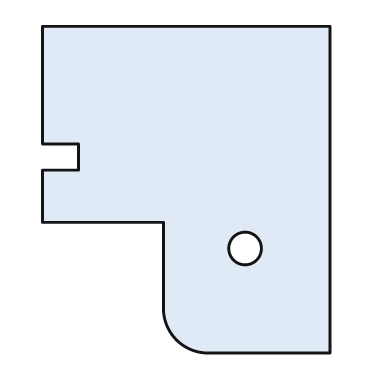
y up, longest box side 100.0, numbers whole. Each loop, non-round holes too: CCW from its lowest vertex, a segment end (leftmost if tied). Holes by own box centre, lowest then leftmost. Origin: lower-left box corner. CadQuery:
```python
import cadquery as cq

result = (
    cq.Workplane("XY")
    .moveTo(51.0, 0.0)
    .lineTo(88.0, 0.0)
    .lineTo(88.0, 100.0)
    .lineTo(0.0, 100.0)
    .lineTo(0.0, 64.0)
    .lineTo(11.0, 64.0)
    .lineTo(11.0, 56.0)
    .lineTo(0.0, 56.0)
    .lineTo(0.0, 40.0)
    .lineTo(37.0, 40.0)
    .lineTo(37.0, 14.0)
    .threePointArc((41.0, 4.0), (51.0, 0.0))
    .close()
    .moveTo(62.0, 32.0)
    .circle(5.0)
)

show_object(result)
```